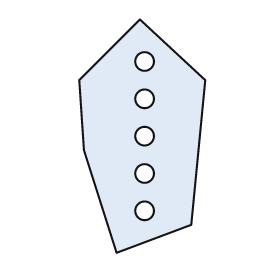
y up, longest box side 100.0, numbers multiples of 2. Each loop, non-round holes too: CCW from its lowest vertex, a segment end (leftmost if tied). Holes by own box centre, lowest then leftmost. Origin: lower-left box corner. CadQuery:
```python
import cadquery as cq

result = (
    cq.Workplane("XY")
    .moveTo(16.0, 0.0)
    .lineTo(48.0, 12.0)
    .lineTo(54.0, 74.0)
    .lineTo(26.0, 100.0)
    .lineTo(0.0, 74.0)
    .lineTo(2.0, 44.0)
    .close()
    .moveTo(28.0, 18.0)
    .circle(4.0)
    .moveTo(28.0, 34.0)
    .circle(4.0)
    .moveTo(28.0, 50.0)
    .circle(4.0)
    .moveTo(28.0, 66.0)
    .circle(4.0)
    .moveTo(28.0, 82.0)
    .circle(4.0)
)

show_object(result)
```